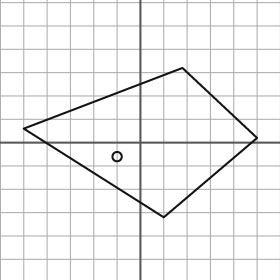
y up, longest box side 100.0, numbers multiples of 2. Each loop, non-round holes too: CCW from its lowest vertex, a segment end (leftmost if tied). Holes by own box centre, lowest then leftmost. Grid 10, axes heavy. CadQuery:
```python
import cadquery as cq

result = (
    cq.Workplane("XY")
    .moveTo(10.0, -32.0)
    .lineTo(50.0, 2.0)
    .lineTo(18.0, 32.0)
    .lineTo(-50.0, 6.0)
    .close()
    .moveTo(-10.0, -6.0)
    .circle(2.0)
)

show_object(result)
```